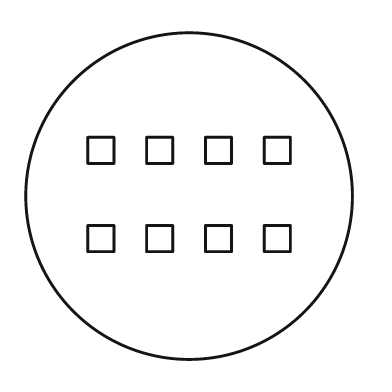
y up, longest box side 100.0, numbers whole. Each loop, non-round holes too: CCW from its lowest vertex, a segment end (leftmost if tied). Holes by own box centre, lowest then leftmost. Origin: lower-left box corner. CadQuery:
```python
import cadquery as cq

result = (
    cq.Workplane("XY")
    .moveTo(50.0, 50.0)
    .circle(50.0)
    .moveTo(19.0, 33.0)
    .lineTo(27.0, 33.0)
    .lineTo(27.0, 41.0)
    .lineTo(19.0, 41.0)
    .close()
    .moveTo(37.0, 33.0)
    .lineTo(45.0, 33.0)
    .lineTo(45.0, 41.0)
    .lineTo(37.0, 41.0)
    .close()
    .moveTo(55.0, 33.0)
    .lineTo(63.0, 33.0)
    .lineTo(63.0, 41.0)
    .lineTo(55.0, 41.0)
    .close()
    .moveTo(73.0, 33.0)
    .lineTo(81.0, 33.0)
    .lineTo(81.0, 41.0)
    .lineTo(73.0, 41.0)
    .close()
    .moveTo(19.0, 60.0)
    .lineTo(27.0, 60.0)
    .lineTo(27.0, 68.0)
    .lineTo(19.0, 68.0)
    .close()
    .moveTo(37.0, 60.0)
    .lineTo(45.0, 60.0)
    .lineTo(45.0, 68.0)
    .lineTo(37.0, 68.0)
    .close()
    .moveTo(55.0, 60.0)
    .lineTo(63.0, 60.0)
    .lineTo(63.0, 68.0)
    .lineTo(55.0, 68.0)
    .close()
    .moveTo(73.0, 60.0)
    .lineTo(81.0, 60.0)
    .lineTo(81.0, 68.0)
    .lineTo(73.0, 68.0)
    .close()
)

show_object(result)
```